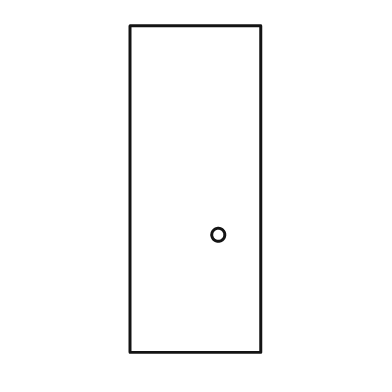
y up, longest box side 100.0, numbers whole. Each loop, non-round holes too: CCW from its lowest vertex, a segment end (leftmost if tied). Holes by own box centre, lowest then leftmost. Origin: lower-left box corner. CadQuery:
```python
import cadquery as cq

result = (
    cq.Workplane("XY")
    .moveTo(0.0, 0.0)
    .lineTo(40.0, 0.0)
    .lineTo(40.0, 100.0)
    .lineTo(0.0, 100.0)
    .close()
    .moveTo(27.0, 36.0)
    .circle(2.0)
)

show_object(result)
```